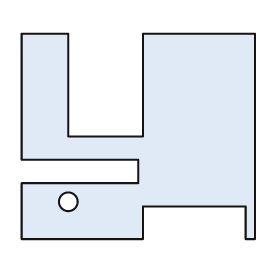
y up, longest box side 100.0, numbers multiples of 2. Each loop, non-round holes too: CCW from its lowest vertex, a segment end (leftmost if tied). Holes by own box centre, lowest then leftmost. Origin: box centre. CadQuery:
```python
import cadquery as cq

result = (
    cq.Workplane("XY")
    .moveTo(-50.0, -44.0)
    .lineTo(2.0, -44.0)
    .lineTo(2.0, -30.0)
    .lineTo(46.0, -30.0)
    .lineTo(46.0, -44.0)
    .lineTo(50.0, -44.0)
    .lineTo(50.0, 44.0)
    .lineTo(2.0, 44.0)
    .lineTo(2.0, 0.0)
    .lineTo(-30.0, 0.0)
    .lineTo(-30.0, 44.0)
    .lineTo(-50.0, 44.0)
    .lineTo(-50.0, -10.0)
    .lineTo(0.0, -10.0)
    .lineTo(0.0, -20.0)
    .lineTo(-50.0, -20.0)
    .close()
    .moveTo(-30.0, -28.0)
    .circle(4.0)
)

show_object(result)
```